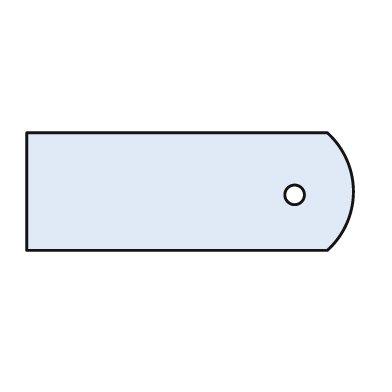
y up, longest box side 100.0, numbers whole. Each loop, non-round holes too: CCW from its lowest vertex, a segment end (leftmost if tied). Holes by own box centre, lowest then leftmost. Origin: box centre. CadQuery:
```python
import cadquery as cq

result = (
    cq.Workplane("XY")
    .moveTo(-50.0, -18.0)
    .lineTo(42.0, -18.0)
    .threePointArc((50.0, 0.0), (42.0, 18.0))
    .lineTo(-50.0, 18.0)
    .close()
    .moveTo(32.0, -1.0)
    .circle(3.0)
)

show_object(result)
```